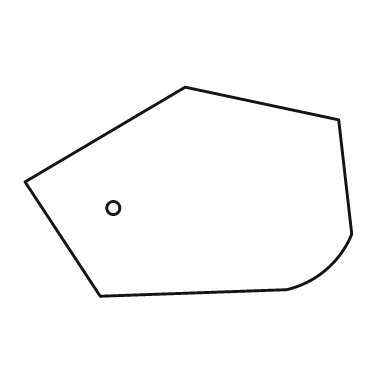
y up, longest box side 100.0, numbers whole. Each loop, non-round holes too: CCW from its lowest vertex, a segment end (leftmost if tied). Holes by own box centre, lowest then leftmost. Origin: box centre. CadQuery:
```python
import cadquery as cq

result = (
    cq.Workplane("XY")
    .moveTo(-27.0, -32.0)
    .lineTo(30.0, -30.0)
    .threePointArc((42.0, -24.0), (50.0, -13.0))
    .lineTo(46.0, 22.0)
    .lineTo(-1.0, 32.0)
    .lineTo(-50.0, 3.0)
    .close()
    .moveTo(-23.0, -5.0)
    .circle(2.0)
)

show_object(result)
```